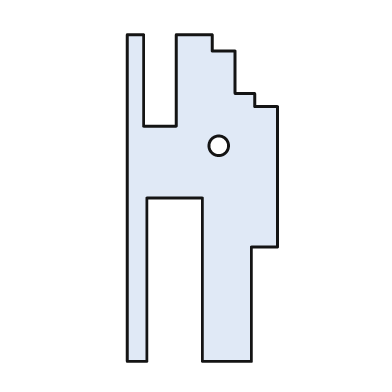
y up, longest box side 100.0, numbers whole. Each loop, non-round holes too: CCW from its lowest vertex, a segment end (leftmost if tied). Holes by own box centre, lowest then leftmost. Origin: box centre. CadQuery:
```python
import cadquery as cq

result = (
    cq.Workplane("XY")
    .moveTo(-23.0, -50.0)
    .lineTo(-17.0, -50.0)
    .lineTo(-17.0, 0.0)
    .lineTo(0.0, 0.0)
    .lineTo(0.0, -50.0)
    .lineTo(15.0, -50.0)
    .lineTo(15.0, -15.0)
    .lineTo(23.0, -15.0)
    .lineTo(23.0, 28.0)
    .lineTo(16.0, 28.0)
    .lineTo(16.0, 32.0)
    .lineTo(10.0, 32.0)
    .lineTo(10.0, 45.0)
    .lineTo(3.0, 45.0)
    .lineTo(3.0, 50.0)
    .lineTo(-8.0, 50.0)
    .lineTo(-8.0, 22.0)
    .lineTo(-18.0, 22.0)
    .lineTo(-18.0, 50.0)
    .lineTo(-23.0, 50.0)
    .close()
    .moveTo(5.0, 16.0)
    .circle(3.0)
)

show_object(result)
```